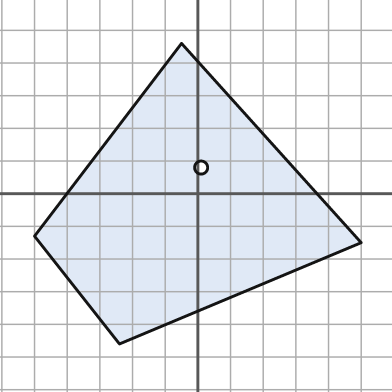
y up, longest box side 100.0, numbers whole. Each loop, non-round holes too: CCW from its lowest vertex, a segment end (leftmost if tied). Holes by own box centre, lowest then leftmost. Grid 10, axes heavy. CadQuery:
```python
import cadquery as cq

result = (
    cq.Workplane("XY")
    .moveTo(-24.0, -46.0)
    .lineTo(50.0, -15.0)
    .lineTo(-5.0, 46.0)
    .lineTo(-50.0, -13.0)
    .close()
    .moveTo(1.0, 8.0)
    .circle(2.0)
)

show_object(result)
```